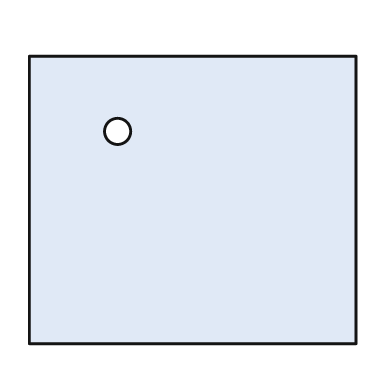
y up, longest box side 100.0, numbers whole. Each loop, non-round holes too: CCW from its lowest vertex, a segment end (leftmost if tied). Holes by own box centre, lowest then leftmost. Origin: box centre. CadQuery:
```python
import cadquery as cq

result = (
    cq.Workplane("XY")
    .moveTo(-50.0, -44.0)
    .lineTo(50.0, -44.0)
    .lineTo(50.0, 44.0)
    .lineTo(-50.0, 44.0)
    .close()
    .moveTo(-23.0, 21.0)
    .circle(4.0)
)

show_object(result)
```